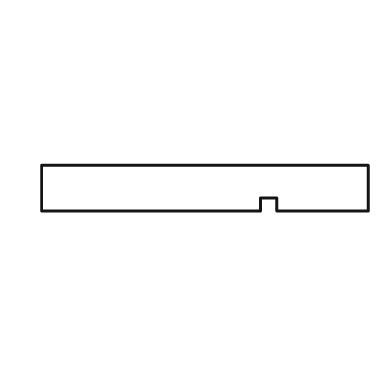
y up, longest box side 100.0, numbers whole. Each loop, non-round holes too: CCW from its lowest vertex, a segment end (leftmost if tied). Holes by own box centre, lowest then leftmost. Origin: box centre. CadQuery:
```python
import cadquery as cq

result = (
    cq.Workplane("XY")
    .moveTo(-50.0, -7.0)
    .lineTo(17.0, -7.0)
    .lineTo(17.0, -3.0)
    .lineTo(22.0, -3.0)
    .lineTo(22.0, -7.0)
    .lineTo(50.0, -7.0)
    .lineTo(50.0, 7.0)
    .lineTo(-50.0, 7.0)
    .close()
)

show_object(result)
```